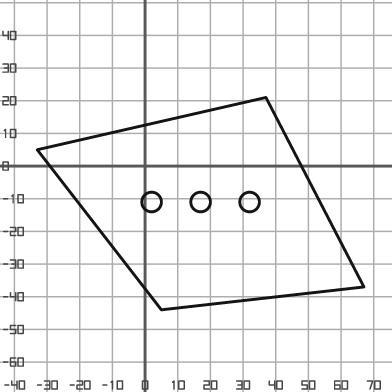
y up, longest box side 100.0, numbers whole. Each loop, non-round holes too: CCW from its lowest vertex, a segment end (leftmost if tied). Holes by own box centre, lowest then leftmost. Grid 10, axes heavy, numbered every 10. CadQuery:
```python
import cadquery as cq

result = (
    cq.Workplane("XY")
    .moveTo(5.0, -44.0)
    .lineTo(67.0, -37.0)
    .lineTo(37.0, 21.0)
    .lineTo(-33.0, 5.0)
    .close()
    .moveTo(2.0, -11.0)
    .circle(3.0)
    .moveTo(17.0, -11.0)
    .circle(3.0)
    .moveTo(32.0, -11.0)
    .circle(3.0)
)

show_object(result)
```